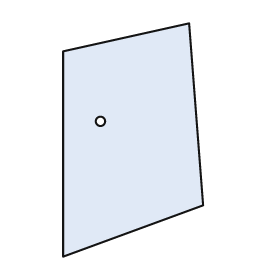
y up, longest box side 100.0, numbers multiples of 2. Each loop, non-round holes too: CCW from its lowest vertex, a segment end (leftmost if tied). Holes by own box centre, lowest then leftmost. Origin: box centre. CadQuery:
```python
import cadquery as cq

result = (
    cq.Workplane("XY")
    .moveTo(-30.0, -50.0)
    .lineTo(30.0, -28.0)
    .lineTo(24.0, 50.0)
    .lineTo(-30.0, 38.0)
    .close()
    .moveTo(-14.0, 8.0)
    .circle(2.0)
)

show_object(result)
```